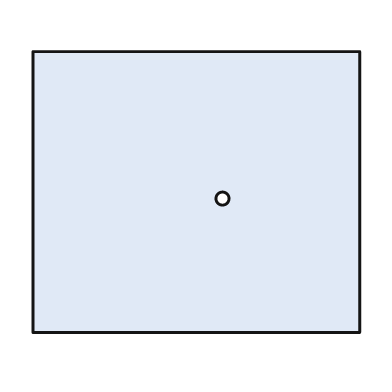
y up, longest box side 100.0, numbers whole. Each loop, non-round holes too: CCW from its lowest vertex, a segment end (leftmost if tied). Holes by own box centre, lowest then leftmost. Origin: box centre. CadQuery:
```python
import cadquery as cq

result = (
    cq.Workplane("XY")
    .moveTo(-50.0, -43.0)
    .lineTo(50.0, -43.0)
    .lineTo(50.0, 43.0)
    .lineTo(-50.0, 43.0)
    .close()
    .moveTo(8.0, -2.0)
    .circle(2.0)
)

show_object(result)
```